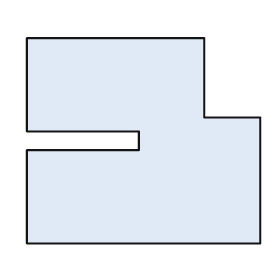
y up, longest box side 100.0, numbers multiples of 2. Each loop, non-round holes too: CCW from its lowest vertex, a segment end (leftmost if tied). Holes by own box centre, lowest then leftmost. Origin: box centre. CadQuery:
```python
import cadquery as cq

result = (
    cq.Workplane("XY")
    .moveTo(-50.0, -44.0)
    .lineTo(50.0, -44.0)
    .lineTo(50.0, 10.0)
    .lineTo(26.0, 10.0)
    .lineTo(26.0, 44.0)
    .lineTo(-50.0, 44.0)
    .lineTo(-50.0, 4.0)
    .lineTo(-2.0, 4.0)
    .lineTo(-2.0, -4.0)
    .lineTo(-50.0, -4.0)
    .close()
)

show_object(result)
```